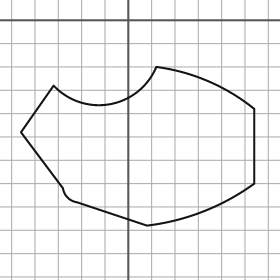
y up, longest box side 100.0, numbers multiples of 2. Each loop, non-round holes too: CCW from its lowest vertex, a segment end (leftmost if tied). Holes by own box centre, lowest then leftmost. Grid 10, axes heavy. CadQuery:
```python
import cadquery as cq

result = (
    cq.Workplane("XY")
    .moveTo(8.0, -88.0)
    .threePointArc((32.0, -82.0), (54.0, -70.0))
    .lineTo(54.0, -38.0)
    .threePointArc((34.0, -26.0), (12.0, -20.0))
    .threePointArc((-8.0, -36.0), (-32.0, -28.0))
    .lineTo(-46.0, -48.0)
    .lineTo(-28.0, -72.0)
    .threePointArc((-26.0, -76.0), (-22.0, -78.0))
    .close()
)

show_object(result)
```